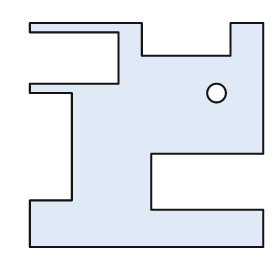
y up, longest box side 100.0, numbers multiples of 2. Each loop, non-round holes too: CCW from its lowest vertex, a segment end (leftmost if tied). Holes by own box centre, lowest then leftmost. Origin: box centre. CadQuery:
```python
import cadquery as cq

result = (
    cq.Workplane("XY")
    .moveTo(-50.0, -48.0)
    .lineTo(50.0, -48.0)
    .lineTo(50.0, -32.0)
    .lineTo(2.0, -32.0)
    .lineTo(2.0, -8.0)
    .lineTo(50.0, -8.0)
    .lineTo(50.0, 48.0)
    .lineTo(36.0, 48.0)
    .lineTo(36.0, 34.0)
    .lineTo(-2.0, 34.0)
    .lineTo(-2.0, 48.0)
    .lineTo(-50.0, 48.0)
    .lineTo(-50.0, 44.0)
    .lineTo(-12.0, 44.0)
    .lineTo(-12.0, 22.0)
    .lineTo(-50.0, 22.0)
    .lineTo(-50.0, 18.0)
    .lineTo(-32.0, 18.0)
    .lineTo(-32.0, -28.0)
    .lineTo(-50.0, -28.0)
    .close()
    .moveTo(30.0, 18.0)
    .circle(4.0)
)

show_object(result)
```